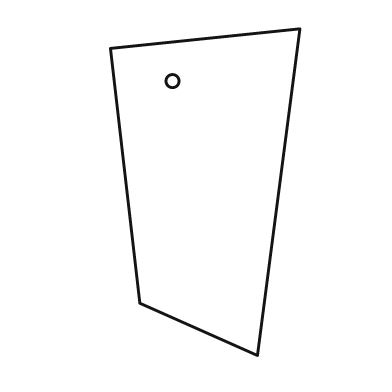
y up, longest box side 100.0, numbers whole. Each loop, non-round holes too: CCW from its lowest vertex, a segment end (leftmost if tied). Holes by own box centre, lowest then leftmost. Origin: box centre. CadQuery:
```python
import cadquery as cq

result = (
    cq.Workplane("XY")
    .moveTo(16.0, -50.0)
    .lineTo(29.0, 50.0)
    .lineTo(-29.0, 44.0)
    .lineTo(-20.0, -34.0)
    .close()
    .moveTo(-10.0, 34.0)
    .circle(2.0)
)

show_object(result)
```